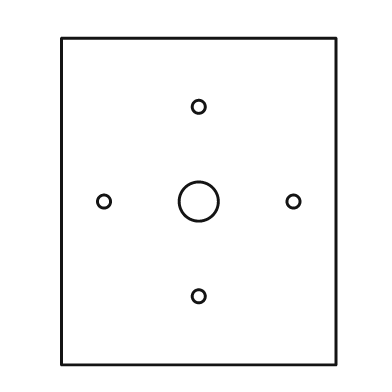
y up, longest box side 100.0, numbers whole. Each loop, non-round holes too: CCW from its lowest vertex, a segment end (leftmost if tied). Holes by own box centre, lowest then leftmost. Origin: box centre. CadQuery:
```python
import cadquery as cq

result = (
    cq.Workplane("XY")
    .moveTo(-42.0, -50.0)
    .lineTo(42.0, -50.0)
    .lineTo(42.0, 50.0)
    .lineTo(-42.0, 50.0)
    .close()
    .moveTo(0.0, -29.0)
    .circle(2.0)
    .moveTo(-29.0, 0.0)
    .circle(2.0)
    .moveTo(0.0, 0.0)
    .circle(6.0)
    .moveTo(29.0, 0.0)
    .circle(2.0)
    .moveTo(0.0, 29.0)
    .circle(2.0)
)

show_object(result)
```